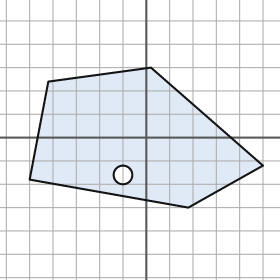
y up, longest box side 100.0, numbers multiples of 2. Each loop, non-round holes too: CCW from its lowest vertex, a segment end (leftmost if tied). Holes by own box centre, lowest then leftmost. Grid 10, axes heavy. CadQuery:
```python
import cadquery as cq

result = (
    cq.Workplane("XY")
    .moveTo(18.0, -30.0)
    .lineTo(50.0, -12.0)
    .lineTo(2.0, 30.0)
    .lineTo(-42.0, 24.0)
    .lineTo(-50.0, -18.0)
    .close()
    .moveTo(-10.0, -16.0)
    .circle(4.0)
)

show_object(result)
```